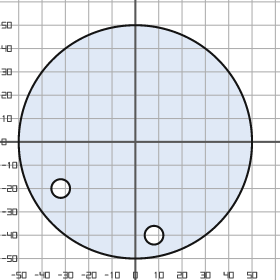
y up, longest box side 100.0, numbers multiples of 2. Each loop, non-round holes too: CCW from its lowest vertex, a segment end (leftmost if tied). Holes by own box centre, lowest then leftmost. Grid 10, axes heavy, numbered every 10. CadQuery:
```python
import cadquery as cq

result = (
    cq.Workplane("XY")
    .moveTo(0.0, 0.0)
    .circle(50.0)
    .moveTo(8.0, -40.0)
    .circle(4.0)
    .moveTo(-32.0, -20.0)
    .circle(4.0)
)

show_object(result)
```